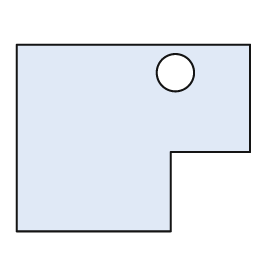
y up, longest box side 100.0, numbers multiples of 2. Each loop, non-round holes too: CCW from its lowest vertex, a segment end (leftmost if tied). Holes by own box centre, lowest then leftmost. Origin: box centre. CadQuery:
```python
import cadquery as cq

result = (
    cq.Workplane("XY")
    .moveTo(-50.0, -40.0)
    .lineTo(16.0, -40.0)
    .lineTo(16.0, -6.0)
    .lineTo(50.0, -6.0)
    .lineTo(50.0, 40.0)
    .lineTo(-50.0, 40.0)
    .close()
    .moveTo(18.0, 28.0)
    .circle(8.0)
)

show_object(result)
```